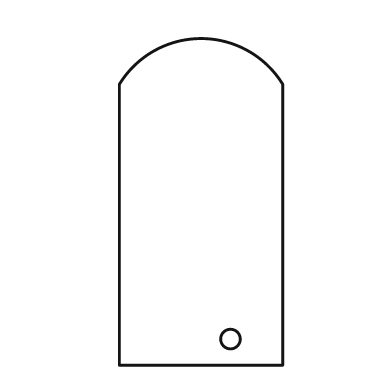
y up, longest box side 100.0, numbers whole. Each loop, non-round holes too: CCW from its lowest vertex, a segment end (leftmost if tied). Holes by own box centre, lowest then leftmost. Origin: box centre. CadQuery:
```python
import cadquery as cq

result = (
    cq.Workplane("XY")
    .moveTo(-25.0, -50.0)
    .lineTo(25.0, -50.0)
    .lineTo(25.0, 36.0)
    .threePointArc((0.0, 50.0), (-25.0, 36.0))
    .close()
    .moveTo(9.0, -42.0)
    .circle(3.0)
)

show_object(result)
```